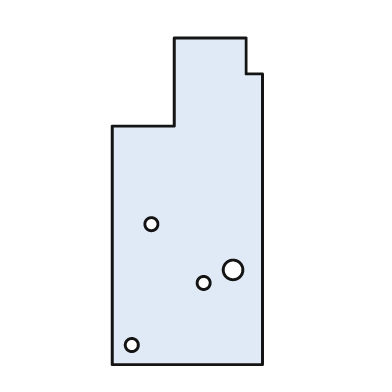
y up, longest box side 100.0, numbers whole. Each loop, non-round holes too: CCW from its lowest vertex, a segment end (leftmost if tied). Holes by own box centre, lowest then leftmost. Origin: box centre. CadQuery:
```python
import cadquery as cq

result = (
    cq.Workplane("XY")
    .moveTo(-23.0, -50.0)
    .lineTo(23.0, -50.0)
    .lineTo(23.0, 39.0)
    .lineTo(18.0, 39.0)
    .lineTo(18.0, 50.0)
    .lineTo(-4.0, 50.0)
    .lineTo(-4.0, 23.0)
    .lineTo(-23.0, 23.0)
    .close()
    .moveTo(-17.0, -44.0)
    .circle(2.0)
    .moveTo(5.0, -25.0)
    .circle(2.0)
    .moveTo(14.0, -21.0)
    .circle(3.0)
    .moveTo(-11.0, -7.0)
    .circle(2.0)
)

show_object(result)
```